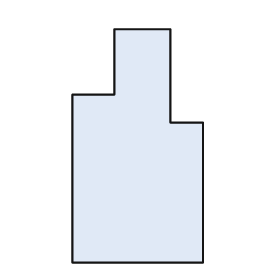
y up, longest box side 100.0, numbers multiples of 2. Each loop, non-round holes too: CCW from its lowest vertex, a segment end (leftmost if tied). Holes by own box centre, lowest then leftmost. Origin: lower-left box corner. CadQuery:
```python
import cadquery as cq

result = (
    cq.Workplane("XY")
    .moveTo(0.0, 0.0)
    .lineTo(56.0, 0.0)
    .lineTo(56.0, 60.0)
    .lineTo(42.0, 60.0)
    .lineTo(42.0, 100.0)
    .lineTo(18.0, 100.0)
    .lineTo(18.0, 72.0)
    .lineTo(0.0, 72.0)
    .close()
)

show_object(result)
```